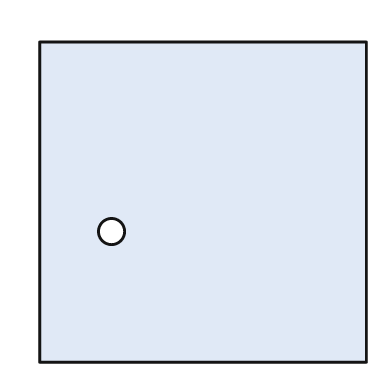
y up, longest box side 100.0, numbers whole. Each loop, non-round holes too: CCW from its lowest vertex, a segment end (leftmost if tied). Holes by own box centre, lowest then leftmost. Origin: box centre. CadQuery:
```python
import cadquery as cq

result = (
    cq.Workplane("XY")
    .moveTo(-50.0, -49.0)
    .lineTo(50.0, -49.0)
    .lineTo(50.0, 49.0)
    .lineTo(-50.0, 49.0)
    .close()
    .moveTo(-28.0, -9.0)
    .circle(4.0)
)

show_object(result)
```